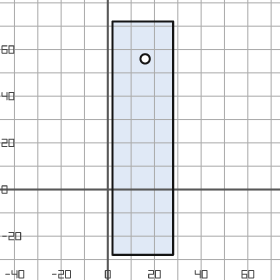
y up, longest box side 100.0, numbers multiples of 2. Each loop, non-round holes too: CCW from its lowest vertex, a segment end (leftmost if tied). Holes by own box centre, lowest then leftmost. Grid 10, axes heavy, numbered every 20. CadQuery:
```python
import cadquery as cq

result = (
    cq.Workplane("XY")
    .moveTo(2.0, -28.0)
    .lineTo(28.0, -28.0)
    .lineTo(28.0, 72.0)
    .lineTo(2.0, 72.0)
    .close()
    .moveTo(16.0, 56.0)
    .circle(2.0)
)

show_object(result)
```